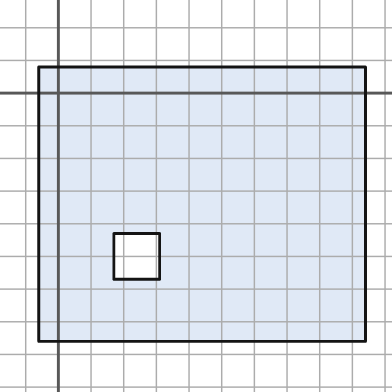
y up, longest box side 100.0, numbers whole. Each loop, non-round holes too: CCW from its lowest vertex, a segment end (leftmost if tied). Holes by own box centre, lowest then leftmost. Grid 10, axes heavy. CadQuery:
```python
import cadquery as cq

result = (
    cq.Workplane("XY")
    .moveTo(-6.0, -76.0)
    .lineTo(94.0, -76.0)
    .lineTo(94.0, 8.0)
    .lineTo(-6.0, 8.0)
    .close()
    .moveTo(17.0, -57.0)
    .lineTo(31.0, -57.0)
    .lineTo(31.0, -43.0)
    .lineTo(17.0, -43.0)
    .close()
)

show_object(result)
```